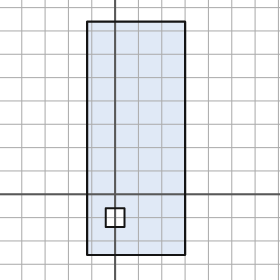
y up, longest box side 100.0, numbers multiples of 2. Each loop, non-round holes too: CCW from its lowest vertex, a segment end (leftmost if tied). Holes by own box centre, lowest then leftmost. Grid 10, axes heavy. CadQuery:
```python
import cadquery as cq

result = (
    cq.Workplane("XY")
    .moveTo(-12.0, -26.0)
    .lineTo(30.0, -26.0)
    .lineTo(30.0, 74.0)
    .lineTo(-12.0, 74.0)
    .close()
    .moveTo(-4.0, -14.0)
    .lineTo(4.0, -14.0)
    .lineTo(4.0, -6.0)
    .lineTo(-4.0, -6.0)
    .close()
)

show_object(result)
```